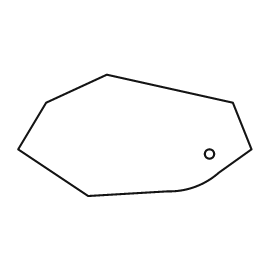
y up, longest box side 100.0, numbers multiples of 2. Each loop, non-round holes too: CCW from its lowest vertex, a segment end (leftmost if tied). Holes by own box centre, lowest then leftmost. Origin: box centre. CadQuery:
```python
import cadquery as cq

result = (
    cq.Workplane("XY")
    .moveTo(-20.0, -26.0)
    .lineTo(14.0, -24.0)
    .threePointArc((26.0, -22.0), (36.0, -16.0))
    .lineTo(50.0, -6.0)
    .lineTo(42.0, 14.0)
    .lineTo(-12.0, 26.0)
    .lineTo(-38.0, 14.0)
    .lineTo(-50.0, -6.0)
    .close()
    .moveTo(32.0, -8.0)
    .circle(2.0)
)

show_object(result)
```